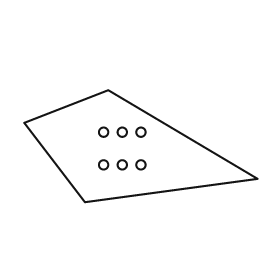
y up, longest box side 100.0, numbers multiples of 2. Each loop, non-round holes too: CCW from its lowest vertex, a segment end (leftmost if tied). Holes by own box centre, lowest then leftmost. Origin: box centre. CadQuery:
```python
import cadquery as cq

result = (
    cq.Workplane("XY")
    .moveTo(-24.0, -24.0)
    .lineTo(50.0, -14.0)
    .lineTo(-14.0, 24.0)
    .lineTo(-50.0, 10.0)
    .close()
    .moveTo(-16.0, -8.0)
    .circle(2.0)
    .moveTo(-8.0, -8.0)
    .circle(2.0)
    .moveTo(0.0, -8.0)
    .circle(2.0)
    .moveTo(-16.0, 6.0)
    .circle(2.0)
    .moveTo(-8.0, 6.0)
    .circle(2.0)
    .moveTo(0.0, 6.0)
    .circle(2.0)
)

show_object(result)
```